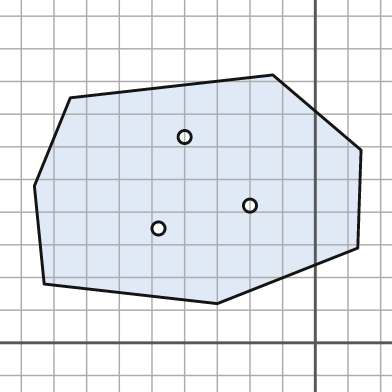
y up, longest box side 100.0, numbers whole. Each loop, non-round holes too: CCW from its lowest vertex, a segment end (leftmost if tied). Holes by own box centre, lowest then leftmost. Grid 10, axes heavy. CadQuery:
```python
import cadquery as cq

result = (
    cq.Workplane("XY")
    .moveTo(-30.0, 12.0)
    .lineTo(13.0, 29.0)
    .lineTo(14.0, 59.0)
    .lineTo(-13.0, 82.0)
    .lineTo(-75.0, 75.0)
    .lineTo(-86.0, 48.0)
    .lineTo(-83.0, 18.0)
    .close()
    .moveTo(-48.0, 35.0)
    .circle(2.0)
    .moveTo(-20.0, 42.0)
    .circle(2.0)
    .moveTo(-40.0, 63.0)
    .circle(2.0)
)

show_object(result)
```